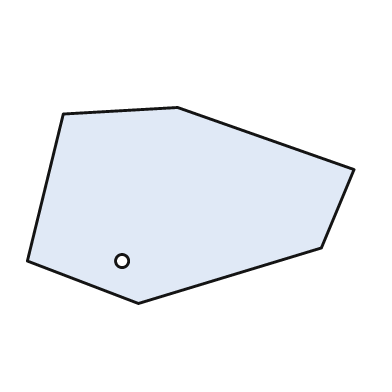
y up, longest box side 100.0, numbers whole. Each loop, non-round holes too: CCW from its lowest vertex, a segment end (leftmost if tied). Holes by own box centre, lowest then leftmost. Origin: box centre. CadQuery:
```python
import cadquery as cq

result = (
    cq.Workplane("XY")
    .moveTo(-16.0, -30.0)
    .lineTo(40.0, -13.0)
    .lineTo(50.0, 11.0)
    .lineTo(-4.0, 30.0)
    .lineTo(-39.0, 28.0)
    .lineTo(-50.0, -17.0)
    .close()
    .moveTo(-21.0, -17.0)
    .circle(2.0)
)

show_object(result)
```